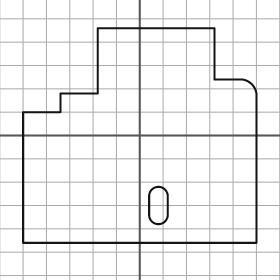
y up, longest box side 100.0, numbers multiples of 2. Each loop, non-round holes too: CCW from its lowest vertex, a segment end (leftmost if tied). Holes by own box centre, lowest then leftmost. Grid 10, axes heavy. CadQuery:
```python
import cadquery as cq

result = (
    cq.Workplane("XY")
    .moveTo(-50.0, -46.0)
    .lineTo(50.0, -46.0)
    .lineTo(50.0, 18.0)
    .threePointArc((48.0, 22.0), (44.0, 24.0))
    .lineTo(32.0, 24.0)
    .lineTo(32.0, 46.0)
    .lineTo(-18.0, 46.0)
    .lineTo(-18.0, 18.0)
    .lineTo(-34.0, 18.0)
    .lineTo(-34.0, 10.0)
    .lineTo(-50.0, 10.0)
    .close()
    .moveTo(4.0, -34.0)
    .threePointArc((8.0, -38.0), (12.0, -34.0))
    .lineTo(12.0, -26.0)
    .threePointArc((8.0, -22.0), (4.0, -26.0))
    .close()
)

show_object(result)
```